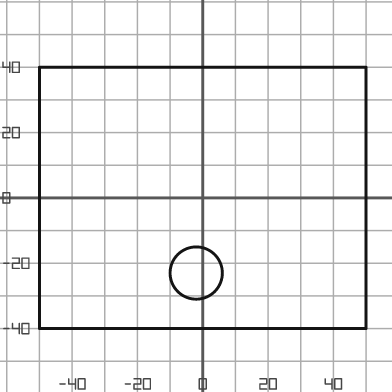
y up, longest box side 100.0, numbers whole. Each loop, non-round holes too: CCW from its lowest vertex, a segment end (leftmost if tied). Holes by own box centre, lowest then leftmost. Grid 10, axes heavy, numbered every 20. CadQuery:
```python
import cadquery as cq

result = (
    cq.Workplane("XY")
    .moveTo(-50.0, -40.0)
    .lineTo(50.0, -40.0)
    .lineTo(50.0, 40.0)
    .lineTo(-50.0, 40.0)
    .close()
    .moveTo(-2.0, -23.0)
    .circle(8.0)
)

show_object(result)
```